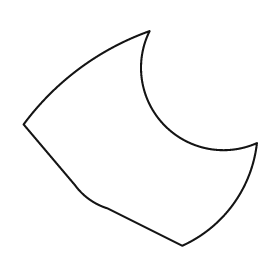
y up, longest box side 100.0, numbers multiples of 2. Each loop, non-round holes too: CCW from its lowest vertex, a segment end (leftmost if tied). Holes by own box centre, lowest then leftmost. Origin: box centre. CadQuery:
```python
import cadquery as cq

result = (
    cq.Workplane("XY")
    .moveTo(18.0, -46.0)
    .threePointArc((40.0, -28.0), (50.0, -2.0))
    .threePointArc((10.0, 6.0), (4.0, 46.0))
    .threePointArc((-26.0, 30.0), (-50.0, 6.0))
    .lineTo(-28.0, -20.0)
    .threePointArc((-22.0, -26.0), (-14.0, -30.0))
    .close()
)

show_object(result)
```